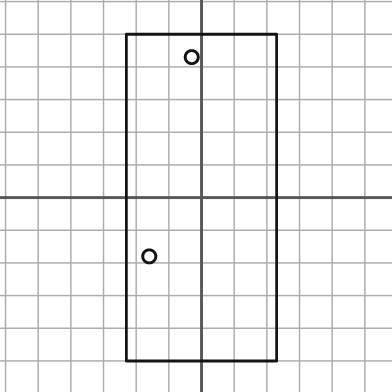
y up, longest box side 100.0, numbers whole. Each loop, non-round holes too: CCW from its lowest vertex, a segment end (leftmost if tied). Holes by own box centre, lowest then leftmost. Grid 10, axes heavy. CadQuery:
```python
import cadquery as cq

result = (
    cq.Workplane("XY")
    .moveTo(-23.0, -50.0)
    .lineTo(23.0, -50.0)
    .lineTo(23.0, 50.0)
    .lineTo(-23.0, 50.0)
    .close()
    .moveTo(-16.0, -18.0)
    .circle(2.0)
    .moveTo(-3.0, 43.0)
    .circle(2.0)
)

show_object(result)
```